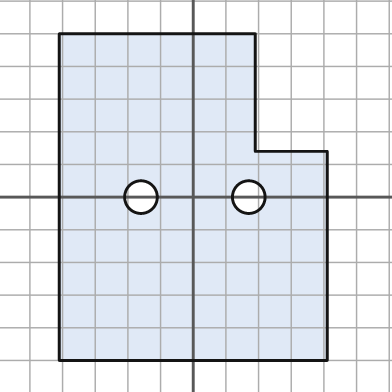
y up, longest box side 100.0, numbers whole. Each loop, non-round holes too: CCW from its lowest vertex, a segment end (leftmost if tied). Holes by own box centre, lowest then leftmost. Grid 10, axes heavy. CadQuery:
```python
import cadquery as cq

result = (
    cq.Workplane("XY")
    .moveTo(-41.0, -50.0)
    .lineTo(41.0, -50.0)
    .lineTo(41.0, 14.0)
    .lineTo(19.0, 14.0)
    .lineTo(19.0, 50.0)
    .lineTo(-41.0, 50.0)
    .close()
    .moveTo(-16.0, 0.0)
    .circle(5.0)
    .moveTo(17.0, 0.0)
    .circle(5.0)
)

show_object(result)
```